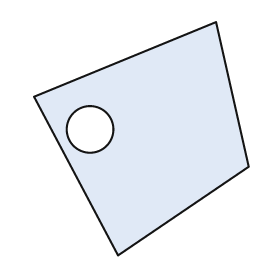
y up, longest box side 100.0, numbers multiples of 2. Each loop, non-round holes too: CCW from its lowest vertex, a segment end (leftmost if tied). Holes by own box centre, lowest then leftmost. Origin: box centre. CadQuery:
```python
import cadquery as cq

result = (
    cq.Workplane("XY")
    .moveTo(-10.0, -50.0)
    .lineTo(46.0, -12.0)
    .lineTo(32.0, 50.0)
    .lineTo(-46.0, 18.0)
    .close()
    .moveTo(-22.0, 4.0)
    .circle(10.0)
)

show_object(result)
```